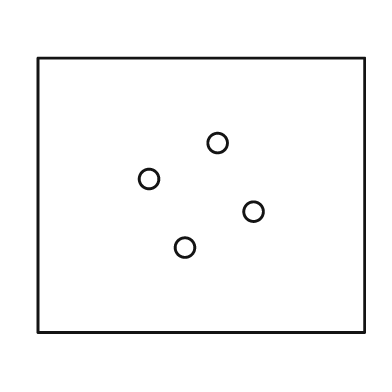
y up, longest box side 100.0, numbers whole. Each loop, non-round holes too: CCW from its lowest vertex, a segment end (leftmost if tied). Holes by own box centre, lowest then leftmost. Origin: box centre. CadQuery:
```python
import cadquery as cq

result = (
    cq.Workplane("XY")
    .moveTo(-50.0, -42.0)
    .lineTo(50.0, -42.0)
    .lineTo(50.0, 42.0)
    .lineTo(-50.0, 42.0)
    .close()
    .moveTo(-5.0, -16.0)
    .circle(3.0)
    .moveTo(16.0, -5.0)
    .circle(3.0)
    .moveTo(-16.0, 5.0)
    .circle(3.0)
    .moveTo(5.0, 16.0)
    .circle(3.0)
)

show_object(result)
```